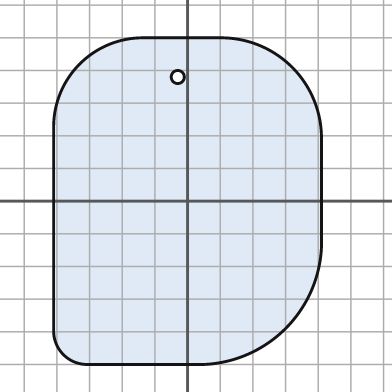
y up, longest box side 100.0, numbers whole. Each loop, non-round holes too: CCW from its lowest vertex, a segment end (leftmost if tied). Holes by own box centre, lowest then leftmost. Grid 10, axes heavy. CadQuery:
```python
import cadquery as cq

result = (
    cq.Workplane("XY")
    .moveTo(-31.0, -50.0)
    .lineTo(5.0, -50.0)
    .threePointArc((30.0, -39.0), (41.0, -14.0))
    .lineTo(41.0, 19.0)
    .threePointArc((32.0, 41.0), (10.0, 50.0))
    .lineTo(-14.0, 50.0)
    .threePointArc((-33.0, 42.0), (-41.0, 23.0))
    .lineTo(-41.0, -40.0)
    .threePointArc((-38.0, -47.0), (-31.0, -50.0))
    .close()
    .moveTo(-3.0, 38.0)
    .circle(2.0)
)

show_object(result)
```